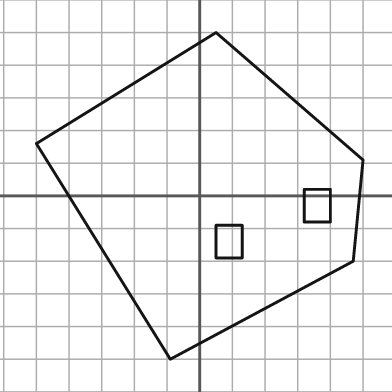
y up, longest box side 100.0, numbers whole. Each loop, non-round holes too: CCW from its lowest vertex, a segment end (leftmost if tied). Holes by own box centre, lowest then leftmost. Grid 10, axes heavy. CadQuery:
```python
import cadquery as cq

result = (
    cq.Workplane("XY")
    .moveTo(-9.0, -50.0)
    .lineTo(47.0, -20.0)
    .lineTo(50.0, 11.0)
    .lineTo(5.0, 50.0)
    .lineTo(-50.0, 16.0)
    .close()
    .moveTo(5.0, -19.0)
    .lineTo(13.0, -19.0)
    .lineTo(13.0, -9.0)
    .lineTo(5.0, -9.0)
    .close()
    .moveTo(32.0, -8.0)
    .lineTo(40.0, -8.0)
    .lineTo(40.0, 2.0)
    .lineTo(32.0, 2.0)
    .close()
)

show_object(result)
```